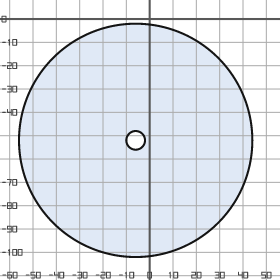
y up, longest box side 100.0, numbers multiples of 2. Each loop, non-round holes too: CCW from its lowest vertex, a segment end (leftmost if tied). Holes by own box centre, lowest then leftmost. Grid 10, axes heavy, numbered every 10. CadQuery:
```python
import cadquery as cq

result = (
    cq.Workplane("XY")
    .moveTo(-6.0, -52.0)
    .circle(50.0)
    .moveTo(-6.0, -52.0)
    .circle(4.0)
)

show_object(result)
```